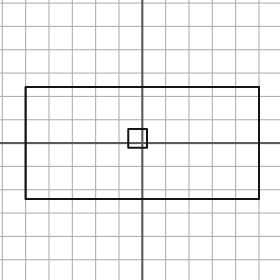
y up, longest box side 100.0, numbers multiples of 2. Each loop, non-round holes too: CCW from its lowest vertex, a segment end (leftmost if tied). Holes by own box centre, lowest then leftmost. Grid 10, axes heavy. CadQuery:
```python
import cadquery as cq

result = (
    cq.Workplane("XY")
    .moveTo(-50.0, -24.0)
    .lineTo(50.0, -24.0)
    .lineTo(50.0, 24.0)
    .lineTo(-50.0, 24.0)
    .close()
    .moveTo(-6.0, -2.0)
    .lineTo(2.0, -2.0)
    .lineTo(2.0, 6.0)
    .lineTo(-6.0, 6.0)
    .close()
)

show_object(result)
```